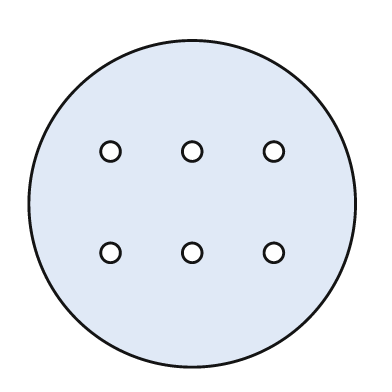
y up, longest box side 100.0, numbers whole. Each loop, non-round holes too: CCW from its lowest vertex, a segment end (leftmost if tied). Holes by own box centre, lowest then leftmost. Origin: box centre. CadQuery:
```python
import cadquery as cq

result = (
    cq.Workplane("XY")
    .moveTo(0.0, 0.0)
    .circle(50.0)
    .moveTo(-25.0, -15.0)
    .circle(3.0)
    .moveTo(0.0, -15.0)
    .circle(3.0)
    .moveTo(25.0, -15.0)
    .circle(3.0)
    .moveTo(-25.0, 16.0)
    .circle(3.0)
    .moveTo(0.0, 16.0)
    .circle(3.0)
    .moveTo(25.0, 16.0)
    .circle(3.0)
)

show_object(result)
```